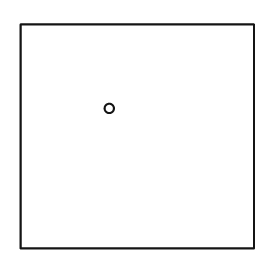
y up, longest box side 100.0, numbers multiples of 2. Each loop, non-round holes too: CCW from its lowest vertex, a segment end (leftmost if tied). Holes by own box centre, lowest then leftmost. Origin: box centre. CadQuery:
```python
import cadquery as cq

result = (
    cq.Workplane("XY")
    .moveTo(-50.0, -48.0)
    .lineTo(50.0, -48.0)
    .lineTo(50.0, 48.0)
    .lineTo(-50.0, 48.0)
    .close()
    .moveTo(-12.0, 12.0)
    .circle(2.0)
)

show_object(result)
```